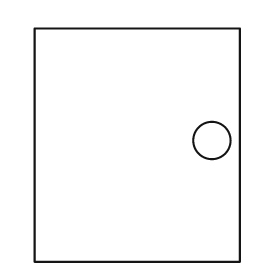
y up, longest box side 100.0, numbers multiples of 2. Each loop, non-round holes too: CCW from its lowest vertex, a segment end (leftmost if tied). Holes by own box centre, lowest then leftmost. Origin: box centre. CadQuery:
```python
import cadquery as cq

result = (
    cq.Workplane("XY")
    .moveTo(-44.0, -50.0)
    .lineTo(44.0, -50.0)
    .lineTo(44.0, 50.0)
    .lineTo(-44.0, 50.0)
    .close()
    .moveTo(32.0, 2.0)
    .circle(8.0)
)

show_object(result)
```